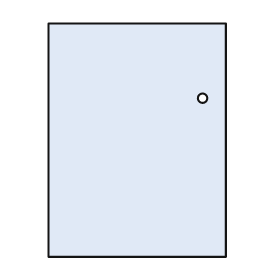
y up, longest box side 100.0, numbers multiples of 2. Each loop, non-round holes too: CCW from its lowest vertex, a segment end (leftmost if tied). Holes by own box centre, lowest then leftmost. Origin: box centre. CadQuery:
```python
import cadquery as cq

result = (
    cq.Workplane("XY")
    .moveTo(-38.0, -50.0)
    .lineTo(38.0, -50.0)
    .lineTo(38.0, 50.0)
    .lineTo(-38.0, 50.0)
    .close()
    .moveTo(28.0, 18.0)
    .circle(2.0)
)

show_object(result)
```